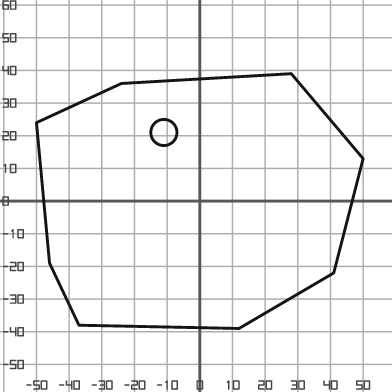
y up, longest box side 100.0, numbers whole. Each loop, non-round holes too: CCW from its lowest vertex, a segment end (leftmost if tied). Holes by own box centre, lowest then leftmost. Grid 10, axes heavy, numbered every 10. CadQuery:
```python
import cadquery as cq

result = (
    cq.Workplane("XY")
    .moveTo(12.0, -39.0)
    .lineTo(41.0, -22.0)
    .lineTo(50.0, 13.0)
    .lineTo(28.0, 39.0)
    .lineTo(-24.0, 36.0)
    .lineTo(-50.0, 24.0)
    .lineTo(-46.0, -19.0)
    .lineTo(-37.0, -38.0)
    .close()
    .moveTo(-11.0, 21.0)
    .circle(4.0)
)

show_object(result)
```